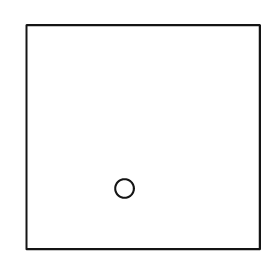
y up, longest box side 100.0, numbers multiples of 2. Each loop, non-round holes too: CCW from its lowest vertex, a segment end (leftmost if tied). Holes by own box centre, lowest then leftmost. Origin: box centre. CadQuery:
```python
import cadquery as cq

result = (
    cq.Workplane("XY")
    .moveTo(-50.0, -48.0)
    .lineTo(50.0, -48.0)
    .lineTo(50.0, 48.0)
    .lineTo(-50.0, 48.0)
    .close()
    .moveTo(-8.0, -22.0)
    .circle(4.0)
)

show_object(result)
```